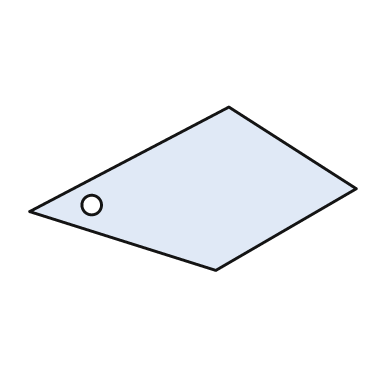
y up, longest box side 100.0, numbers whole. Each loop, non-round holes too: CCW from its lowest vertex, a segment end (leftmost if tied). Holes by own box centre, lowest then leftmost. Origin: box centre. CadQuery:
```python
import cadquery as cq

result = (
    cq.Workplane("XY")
    .moveTo(7.0, -25.0)
    .lineTo(50.0, 0.0)
    .lineTo(11.0, 25.0)
    .lineTo(-50.0, -7.0)
    .close()
    .moveTo(-31.0, -5.0)
    .circle(3.0)
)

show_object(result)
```